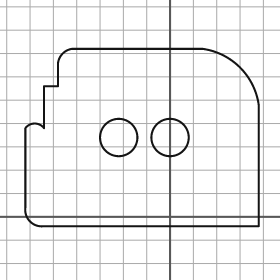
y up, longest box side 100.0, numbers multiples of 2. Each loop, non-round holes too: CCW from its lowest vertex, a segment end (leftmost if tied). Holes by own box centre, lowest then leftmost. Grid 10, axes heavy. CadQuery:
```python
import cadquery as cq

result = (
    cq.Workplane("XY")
    .moveTo(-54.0, -4.0)
    .lineTo(38.0, -4.0)
    .lineTo(38.0, 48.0)
    .threePointArc((30.0, 64.0), (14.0, 72.0))
    .lineTo(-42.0, 72.0)
    .threePointArc((-46.0, 70.0), (-48.0, 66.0))
    .lineTo(-48.0, 56.0)
    .lineTo(-54.0, 56.0)
    .lineTo(-54.0, 38.0)
    .threePointArc((-58.0, 40.0), (-62.0, 38.0))
    .lineTo(-62.0, 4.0)
    .threePointArc((-60.0, -2.0), (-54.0, -4.0))
    .close()
    .moveTo(-22.0, 34.0)
    .circle(8.0)
    .moveTo(0.0, 34.0)
    .circle(8.0)
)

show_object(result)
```